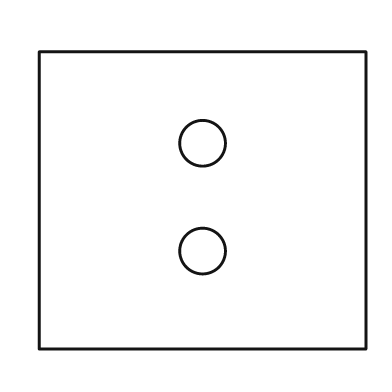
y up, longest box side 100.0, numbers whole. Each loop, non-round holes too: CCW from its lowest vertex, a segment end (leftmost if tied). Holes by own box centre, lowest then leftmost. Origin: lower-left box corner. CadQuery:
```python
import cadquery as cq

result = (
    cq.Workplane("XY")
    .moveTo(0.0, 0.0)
    .lineTo(100.0, 0.0)
    .lineTo(100.0, 91.0)
    .lineTo(0.0, 91.0)
    .close()
    .moveTo(50.0, 30.0)
    .circle(7.0)
    .moveTo(50.0, 63.0)
    .circle(7.0)
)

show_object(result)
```